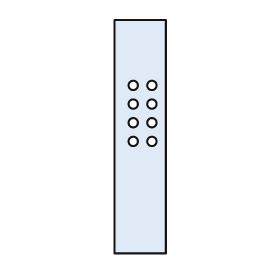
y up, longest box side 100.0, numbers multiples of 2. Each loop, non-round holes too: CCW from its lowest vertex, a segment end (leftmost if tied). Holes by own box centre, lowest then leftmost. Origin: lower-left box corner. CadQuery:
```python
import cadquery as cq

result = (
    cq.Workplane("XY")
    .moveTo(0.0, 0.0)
    .lineTo(22.0, 0.0)
    .lineTo(22.0, 100.0)
    .lineTo(0.0, 100.0)
    .close()
    .moveTo(8.0, 48.0)
    .circle(2.0)
    .moveTo(16.0, 48.0)
    .circle(2.0)
    .moveTo(8.0, 56.0)
    .circle(2.0)
    .moveTo(16.0, 56.0)
    .circle(2.0)
    .moveTo(8.0, 64.0)
    .circle(2.0)
    .moveTo(16.0, 64.0)
    .circle(2.0)
    .moveTo(8.0, 72.0)
    .circle(2.0)
    .moveTo(16.0, 72.0)
    .circle(2.0)
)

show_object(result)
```